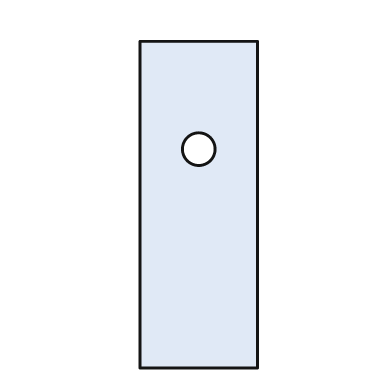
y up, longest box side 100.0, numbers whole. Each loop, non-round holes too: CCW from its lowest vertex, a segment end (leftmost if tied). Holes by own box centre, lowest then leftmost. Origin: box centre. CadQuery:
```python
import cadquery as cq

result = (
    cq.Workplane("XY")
    .moveTo(-18.0, -50.0)
    .lineTo(18.0, -50.0)
    .lineTo(18.0, 50.0)
    .lineTo(-18.0, 50.0)
    .close()
    .moveTo(0.0, 17.0)
    .circle(5.0)
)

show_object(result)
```